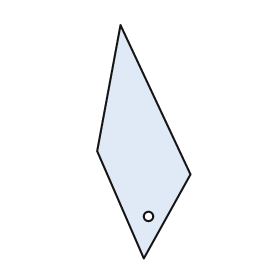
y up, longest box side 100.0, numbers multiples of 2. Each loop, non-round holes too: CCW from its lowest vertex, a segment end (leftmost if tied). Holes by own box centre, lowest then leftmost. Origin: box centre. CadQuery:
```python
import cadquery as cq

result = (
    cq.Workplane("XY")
    .moveTo(0.0, -50.0)
    .lineTo(20.0, -14.0)
    .lineTo(-10.0, 50.0)
    .lineTo(-20.0, -4.0)
    .close()
    .moveTo(2.0, -32.0)
    .circle(2.0)
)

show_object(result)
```